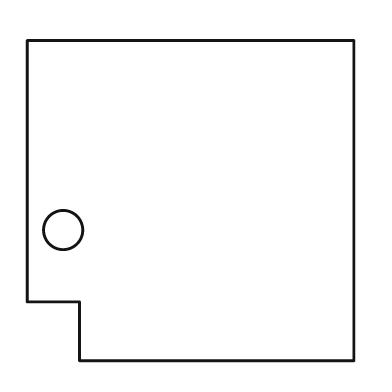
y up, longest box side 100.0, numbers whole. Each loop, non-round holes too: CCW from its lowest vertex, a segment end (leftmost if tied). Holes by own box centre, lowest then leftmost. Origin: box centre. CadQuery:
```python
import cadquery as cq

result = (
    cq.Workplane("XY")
    .moveTo(-34.0, -49.0)
    .lineTo(50.0, -49.0)
    .lineTo(50.0, 49.0)
    .lineTo(-50.0, 49.0)
    .lineTo(-50.0, -31.0)
    .lineTo(-34.0, -31.0)
    .close()
    .moveTo(-39.0, -9.0)
    .circle(6.0)
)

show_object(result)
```